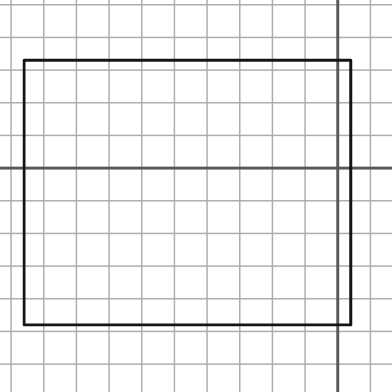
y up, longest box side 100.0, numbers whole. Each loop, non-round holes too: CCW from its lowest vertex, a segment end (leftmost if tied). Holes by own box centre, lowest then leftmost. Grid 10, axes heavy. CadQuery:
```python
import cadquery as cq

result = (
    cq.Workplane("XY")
    .moveTo(-96.0, -48.0)
    .lineTo(4.0, -48.0)
    .lineTo(4.0, 33.0)
    .lineTo(-96.0, 33.0)
    .close()
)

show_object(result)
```